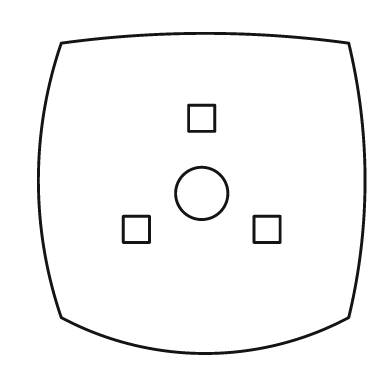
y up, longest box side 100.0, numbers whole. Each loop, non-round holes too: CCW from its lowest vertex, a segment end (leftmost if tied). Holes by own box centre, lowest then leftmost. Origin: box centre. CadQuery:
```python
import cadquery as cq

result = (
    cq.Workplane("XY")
    .moveTo(-43.0, -38.0)
    .threePointArc((1.0, -49.0), (45.0, -38.0))
    .threePointArc((50.0, 4.0), (45.0, 46.0))
    .threePointArc((1.0, 49.0), (-43.0, 46.0))
    .threePointArc((-50.0, 4.0), (-43.0, -38.0))
    .close()
    .moveTo(-24.0, -15.0)
    .lineTo(-16.0, -15.0)
    .lineTo(-16.0, -7.0)
    .lineTo(-24.0, -7.0)
    .close()
    .moveTo(16.0, -15.0)
    .lineTo(24.0, -15.0)
    .lineTo(24.0, -7.0)
    .lineTo(16.0, -7.0)
    .close()
    .moveTo(0.0, 0.0)
    .circle(8.0)
    .moveTo(-4.0, 19.0)
    .lineTo(4.0, 19.0)
    .lineTo(4.0, 27.0)
    .lineTo(-4.0, 27.0)
    .close()
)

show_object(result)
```